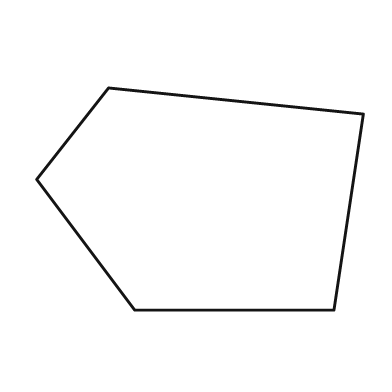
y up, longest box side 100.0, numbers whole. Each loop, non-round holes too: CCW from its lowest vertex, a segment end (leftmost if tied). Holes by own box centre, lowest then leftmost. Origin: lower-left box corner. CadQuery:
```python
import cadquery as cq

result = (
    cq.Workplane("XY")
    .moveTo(30.0, 0.0)
    .lineTo(91.0, 0.0)
    .lineTo(100.0, 60.0)
    .lineTo(22.0, 68.0)
    .lineTo(0.0, 40.0)
    .close()
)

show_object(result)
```